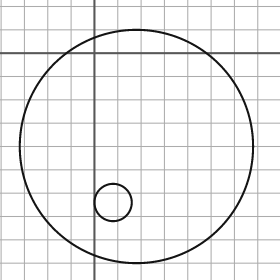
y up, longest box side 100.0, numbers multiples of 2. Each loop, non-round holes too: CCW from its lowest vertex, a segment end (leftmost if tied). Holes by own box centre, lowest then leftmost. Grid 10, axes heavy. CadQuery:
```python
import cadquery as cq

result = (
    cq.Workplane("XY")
    .moveTo(18.0, -40.0)
    .circle(50.0)
    .moveTo(8.0, -64.0)
    .circle(8.0)
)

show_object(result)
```